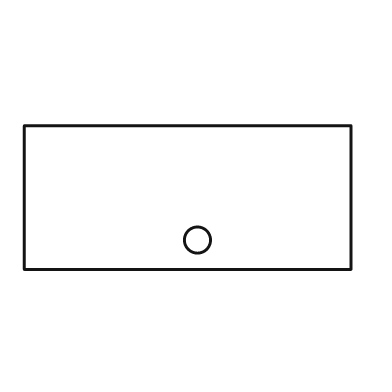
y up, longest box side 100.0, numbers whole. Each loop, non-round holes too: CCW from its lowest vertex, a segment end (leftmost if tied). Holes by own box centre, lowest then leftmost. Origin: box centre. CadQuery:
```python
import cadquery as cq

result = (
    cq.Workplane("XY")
    .moveTo(-50.0, -22.0)
    .lineTo(50.0, -22.0)
    .lineTo(50.0, 22.0)
    .lineTo(-50.0, 22.0)
    .close()
    .moveTo(3.0, -13.0)
    .circle(4.0)
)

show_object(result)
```